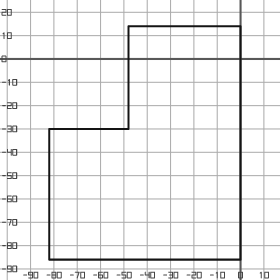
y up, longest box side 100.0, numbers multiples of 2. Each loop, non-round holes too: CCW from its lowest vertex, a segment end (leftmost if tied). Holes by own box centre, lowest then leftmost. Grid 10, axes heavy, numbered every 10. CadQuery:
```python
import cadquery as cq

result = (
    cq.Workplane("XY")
    .moveTo(-82.0, -86.0)
    .lineTo(0.0, -86.0)
    .lineTo(0.0, 14.0)
    .lineTo(-48.0, 14.0)
    .lineTo(-48.0, -30.0)
    .lineTo(-82.0, -30.0)
    .close()
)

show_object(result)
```